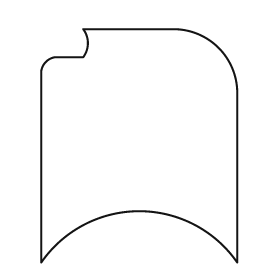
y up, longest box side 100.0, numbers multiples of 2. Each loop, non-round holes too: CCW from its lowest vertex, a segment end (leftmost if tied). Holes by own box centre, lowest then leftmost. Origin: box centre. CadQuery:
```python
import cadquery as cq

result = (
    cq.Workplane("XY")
    .moveTo(-42.0, -50.0)
    .threePointArc((0.0, -28.0), (42.0, -50.0))
    .lineTo(42.0, 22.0)
    .threePointArc((34.0, 42.0), (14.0, 50.0))
    .lineTo(-24.0, 50.0)
    .threePointArc((-22.0, 44.0), (-24.0, 38.0))
    .lineTo(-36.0, 38.0)
    .threePointArc((-40.0, 36.0), (-42.0, 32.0))
    .close()
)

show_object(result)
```